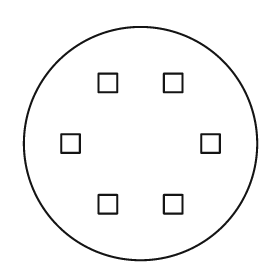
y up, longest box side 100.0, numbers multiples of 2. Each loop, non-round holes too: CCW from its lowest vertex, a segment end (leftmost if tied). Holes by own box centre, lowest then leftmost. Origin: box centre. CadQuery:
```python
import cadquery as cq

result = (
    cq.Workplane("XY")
    .moveTo(0.0, 0.0)
    .circle(50.0)
    .moveTo(-18.0, -30.0)
    .lineTo(-10.0, -30.0)
    .lineTo(-10.0, -22.0)
    .lineTo(-18.0, -22.0)
    .close()
    .moveTo(10.0, -30.0)
    .lineTo(18.0, -30.0)
    .lineTo(18.0, -22.0)
    .lineTo(10.0, -22.0)
    .close()
    .moveTo(-34.0, -4.0)
    .lineTo(-26.0, -4.0)
    .lineTo(-26.0, 4.0)
    .lineTo(-34.0, 4.0)
    .close()
    .moveTo(26.0, -4.0)
    .lineTo(34.0, -4.0)
    .lineTo(34.0, 4.0)
    .lineTo(26.0, 4.0)
    .close()
    .moveTo(-18.0, 22.0)
    .lineTo(-10.0, 22.0)
    .lineTo(-10.0, 30.0)
    .lineTo(-18.0, 30.0)
    .close()
    .moveTo(10.0, 22.0)
    .lineTo(18.0, 22.0)
    .lineTo(18.0, 30.0)
    .lineTo(10.0, 30.0)
    .close()
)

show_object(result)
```